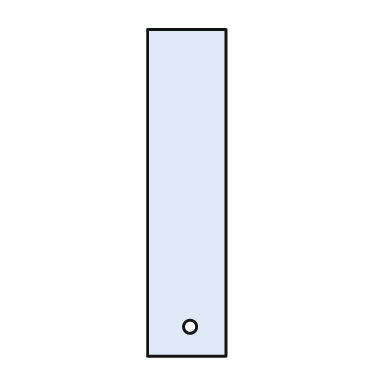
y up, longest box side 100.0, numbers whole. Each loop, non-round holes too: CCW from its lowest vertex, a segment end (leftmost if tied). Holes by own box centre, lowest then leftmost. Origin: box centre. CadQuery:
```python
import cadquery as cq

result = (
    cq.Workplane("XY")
    .moveTo(-12.0, -50.0)
    .lineTo(12.0, -50.0)
    .lineTo(12.0, 50.0)
    .lineTo(-12.0, 50.0)
    .close()
    .moveTo(1.0, -41.0)
    .circle(2.0)
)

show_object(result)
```